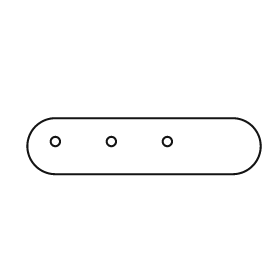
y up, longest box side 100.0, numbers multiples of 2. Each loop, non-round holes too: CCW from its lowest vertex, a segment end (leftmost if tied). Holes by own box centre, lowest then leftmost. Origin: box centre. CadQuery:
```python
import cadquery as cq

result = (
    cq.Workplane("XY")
    .moveTo(-38.0, -12.0)
    .lineTo(38.0, -12.0)
    .threePointArc((50.0, 0.0), (38.0, 12.0))
    .lineTo(-38.0, 12.0)
    .threePointArc((-50.0, 0.0), (-38.0, -12.0))
    .close()
    .moveTo(-38.0, 2.0)
    .circle(2.0)
    .moveTo(-14.0, 2.0)
    .circle(2.0)
    .moveTo(10.0, 2.0)
    .circle(2.0)
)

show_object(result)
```